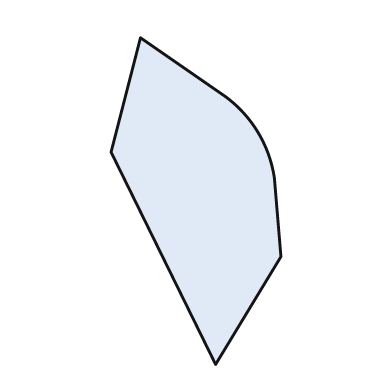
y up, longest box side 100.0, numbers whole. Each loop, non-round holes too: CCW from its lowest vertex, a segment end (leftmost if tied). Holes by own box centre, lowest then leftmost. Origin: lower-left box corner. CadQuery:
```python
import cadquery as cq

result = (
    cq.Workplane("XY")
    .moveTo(32.0, 0.0)
    .lineTo(52.0, 33.0)
    .lineTo(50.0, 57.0)
    .threePointArc((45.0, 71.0), (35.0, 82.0))
    .lineTo(9.0, 100.0)
    .lineTo(0.0, 65.0)
    .close()
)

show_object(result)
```